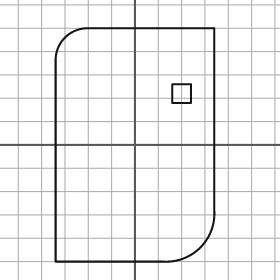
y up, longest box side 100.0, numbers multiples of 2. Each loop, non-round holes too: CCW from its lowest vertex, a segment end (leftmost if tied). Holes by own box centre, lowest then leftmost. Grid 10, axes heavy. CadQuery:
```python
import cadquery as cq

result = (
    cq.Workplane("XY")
    .moveTo(-34.0, -50.0)
    .lineTo(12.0, -50.0)
    .threePointArc((28.0, -44.0), (34.0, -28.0))
    .lineTo(34.0, 50.0)
    .lineTo(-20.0, 50.0)
    .threePointArc((-30.0, 46.0), (-34.0, 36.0))
    .close()
    .moveTo(16.0, 18.0)
    .lineTo(24.0, 18.0)
    .lineTo(24.0, 26.0)
    .lineTo(16.0, 26.0)
    .close()
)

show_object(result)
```